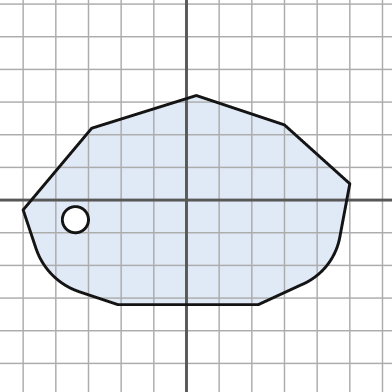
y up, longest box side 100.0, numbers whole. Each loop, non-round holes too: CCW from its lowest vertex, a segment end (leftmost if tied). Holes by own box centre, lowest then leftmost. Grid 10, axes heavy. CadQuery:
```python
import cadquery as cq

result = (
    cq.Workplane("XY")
    .moveTo(-21.0, -32.0)
    .lineTo(22.0, -32.0)
    .lineTo(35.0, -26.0)
    .threePointArc((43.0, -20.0), (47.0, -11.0))
    .lineTo(50.0, 5.0)
    .lineTo(30.0, 23.0)
    .lineTo(3.0, 32.0)
    .lineTo(-29.0, 22.0)
    .lineTo(-50.0, -3.0)
    .lineTo(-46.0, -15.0)
    .threePointArc((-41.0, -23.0), (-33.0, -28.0))
    .close()
    .moveTo(-34.0, -6.0)
    .circle(4.0)
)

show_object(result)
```